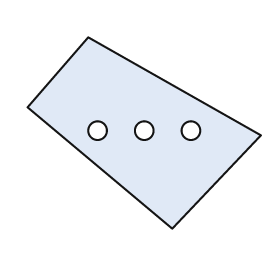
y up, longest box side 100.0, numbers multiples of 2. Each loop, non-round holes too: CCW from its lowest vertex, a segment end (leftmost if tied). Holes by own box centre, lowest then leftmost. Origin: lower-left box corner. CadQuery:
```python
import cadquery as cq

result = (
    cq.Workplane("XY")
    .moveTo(62.0, 0.0)
    .lineTo(100.0, 40.0)
    .lineTo(26.0, 82.0)
    .lineTo(0.0, 52.0)
    .close()
    .moveTo(30.0, 42.0)
    .circle(4.0)
    .moveTo(50.0, 42.0)
    .circle(4.0)
    .moveTo(70.0, 42.0)
    .circle(4.0)
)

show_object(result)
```